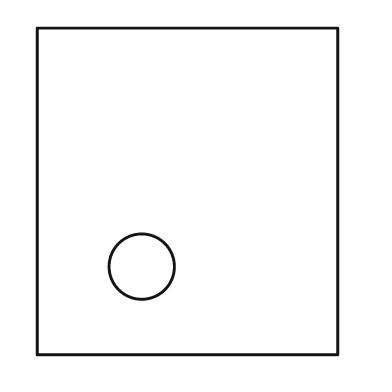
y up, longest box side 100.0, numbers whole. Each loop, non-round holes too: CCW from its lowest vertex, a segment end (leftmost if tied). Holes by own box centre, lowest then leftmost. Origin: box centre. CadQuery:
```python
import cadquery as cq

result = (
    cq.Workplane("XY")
    .moveTo(-46.0, -50.0)
    .lineTo(46.0, -50.0)
    .lineTo(46.0, 50.0)
    .lineTo(-46.0, 50.0)
    .close()
    .moveTo(-14.0, -23.0)
    .circle(10.0)
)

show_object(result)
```